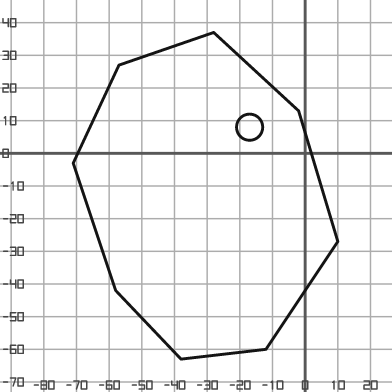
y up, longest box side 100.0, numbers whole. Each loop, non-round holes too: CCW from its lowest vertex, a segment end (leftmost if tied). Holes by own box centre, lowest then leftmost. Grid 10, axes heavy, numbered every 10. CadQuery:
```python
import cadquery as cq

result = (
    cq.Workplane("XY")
    .moveTo(-38.0, -63.0)
    .lineTo(-12.0, -60.0)
    .lineTo(10.0, -27.0)
    .lineTo(-2.0, 13.0)
    .lineTo(-28.0, 37.0)
    .lineTo(-57.0, 27.0)
    .lineTo(-71.0, -3.0)
    .lineTo(-58.0, -42.0)
    .close()
    .moveTo(-17.0, 8.0)
    .circle(4.0)
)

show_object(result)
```